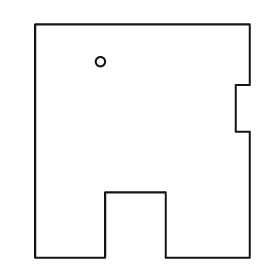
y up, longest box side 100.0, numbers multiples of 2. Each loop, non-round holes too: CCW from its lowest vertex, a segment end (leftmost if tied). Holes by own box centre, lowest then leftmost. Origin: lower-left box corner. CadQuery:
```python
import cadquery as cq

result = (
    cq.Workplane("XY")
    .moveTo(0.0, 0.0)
    .lineTo(30.0, 0.0)
    .lineTo(30.0, 28.0)
    .lineTo(56.0, 28.0)
    .lineTo(56.0, 0.0)
    .lineTo(92.0, 0.0)
    .lineTo(92.0, 54.0)
    .lineTo(86.0, 54.0)
    .lineTo(86.0, 74.0)
    .lineTo(92.0, 74.0)
    .lineTo(92.0, 100.0)
    .lineTo(0.0, 100.0)
    .close()
    .moveTo(28.0, 84.0)
    .circle(2.0)
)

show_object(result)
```